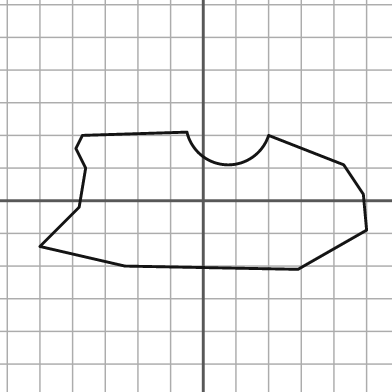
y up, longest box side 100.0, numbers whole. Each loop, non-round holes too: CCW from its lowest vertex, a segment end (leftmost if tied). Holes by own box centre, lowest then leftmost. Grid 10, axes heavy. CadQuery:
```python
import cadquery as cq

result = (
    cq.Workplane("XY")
    .moveTo(29.0, -21.0)
    .lineTo(50.0, -9.0)
    .lineTo(49.0, 2.0)
    .lineTo(43.0, 11.0)
    .lineTo(20.0, 20.0)
    .threePointArc((7.0, 11.0), (-5.0, 21.0))
    .lineTo(-37.0, 20.0)
    .lineTo(-39.0, 16.0)
    .lineTo(-36.0, 10.0)
    .lineTo(-38.0, -2.0)
    .lineTo(-50.0, -14.0)
    .lineTo(-24.0, -20.0)
    .close()
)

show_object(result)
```